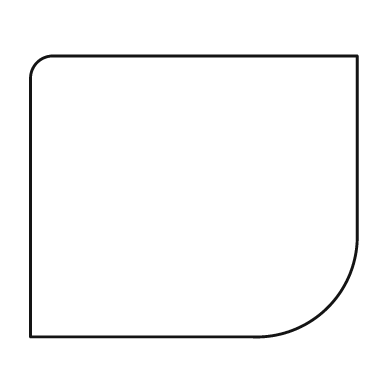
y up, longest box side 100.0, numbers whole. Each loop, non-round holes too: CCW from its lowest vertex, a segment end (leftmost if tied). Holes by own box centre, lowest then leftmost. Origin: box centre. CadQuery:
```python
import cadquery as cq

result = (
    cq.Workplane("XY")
    .moveTo(-50.0, -43.0)
    .lineTo(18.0, -43.0)
    .threePointArc((41.0, -34.0), (50.0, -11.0))
    .lineTo(50.0, 43.0)
    .lineTo(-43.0, 43.0)
    .threePointArc((-48.0, 41.0), (-50.0, 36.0))
    .close()
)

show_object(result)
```